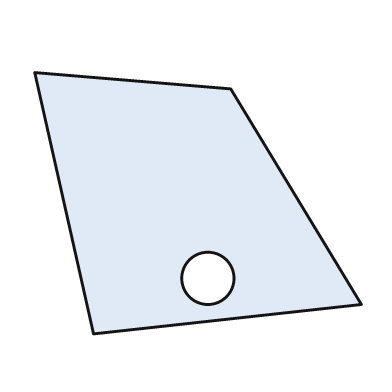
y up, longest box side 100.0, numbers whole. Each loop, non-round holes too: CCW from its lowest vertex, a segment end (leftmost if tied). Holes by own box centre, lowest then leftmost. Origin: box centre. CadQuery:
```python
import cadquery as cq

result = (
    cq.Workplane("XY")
    .moveTo(-32.0, -40.0)
    .lineTo(50.0, -31.0)
    .lineTo(10.0, 35.0)
    .lineTo(-50.0, 40.0)
    .close()
    .moveTo(3.0, -23.0)
    .circle(8.0)
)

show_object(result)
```